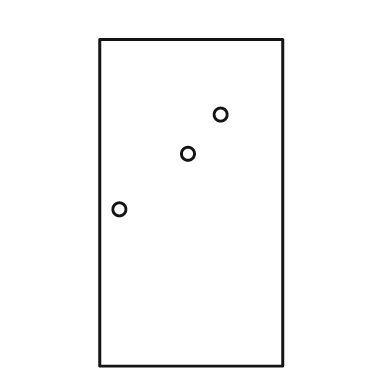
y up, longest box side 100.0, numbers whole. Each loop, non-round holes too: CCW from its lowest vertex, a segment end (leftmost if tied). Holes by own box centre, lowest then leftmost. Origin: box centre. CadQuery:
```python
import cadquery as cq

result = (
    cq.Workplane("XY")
    .moveTo(-28.0, -50.0)
    .lineTo(28.0, -50.0)
    .lineTo(28.0, 50.0)
    .lineTo(-28.0, 50.0)
    .close()
    .moveTo(-22.0, -2.0)
    .circle(2.0)
    .moveTo(-1.0, 15.0)
    .circle(2.0)
    .moveTo(9.0, 27.0)
    .circle(2.0)
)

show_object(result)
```